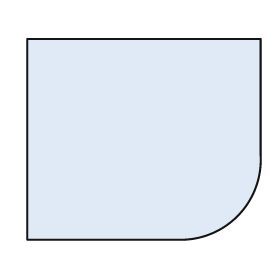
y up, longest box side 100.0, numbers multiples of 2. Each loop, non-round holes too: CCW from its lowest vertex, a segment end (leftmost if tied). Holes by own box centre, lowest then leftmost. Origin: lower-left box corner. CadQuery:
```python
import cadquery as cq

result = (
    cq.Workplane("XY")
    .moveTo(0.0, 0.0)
    .lineTo(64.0, 0.0)
    .threePointArc((90.0, 10.0), (100.0, 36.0))
    .lineTo(100.0, 86.0)
    .lineTo(0.0, 86.0)
    .close()
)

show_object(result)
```